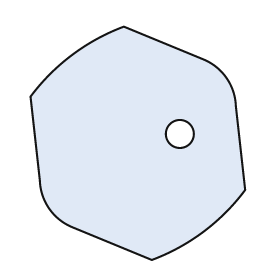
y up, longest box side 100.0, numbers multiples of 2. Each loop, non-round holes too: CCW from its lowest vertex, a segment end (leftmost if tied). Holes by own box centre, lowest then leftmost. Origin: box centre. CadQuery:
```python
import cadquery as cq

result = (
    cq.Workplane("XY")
    .moveTo(6.0, -50.0)
    .threePointArc((28.0, -38.0), (46.0, -20.0))
    .lineTo(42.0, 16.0)
    .threePointArc((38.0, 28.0), (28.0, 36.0))
    .lineTo(-6.0, 50.0)
    .threePointArc((-28.0, 38.0), (-46.0, 20.0))
    .lineTo(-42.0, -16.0)
    .threePointArc((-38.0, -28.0), (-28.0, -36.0))
    .close()
    .moveTo(18.0, 4.0)
    .circle(6.0)
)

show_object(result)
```